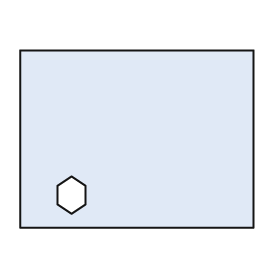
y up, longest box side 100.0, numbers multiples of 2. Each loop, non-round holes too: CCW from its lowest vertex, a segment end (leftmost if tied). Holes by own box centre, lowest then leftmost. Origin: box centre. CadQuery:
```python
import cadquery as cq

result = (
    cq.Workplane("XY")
    .moveTo(-50.0, -38.0)
    .lineTo(50.0, -38.0)
    .lineTo(50.0, 38.0)
    .lineTo(-50.0, 38.0)
    .close()
    .moveTo(-28.0, -32.0)
    .lineTo(-22.0, -28.0)
    .lineTo(-22.0, -20.0)
    .lineTo(-28.0, -16.0)
    .lineTo(-34.0, -20.0)
    .lineTo(-34.0, -28.0)
    .close()
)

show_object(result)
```